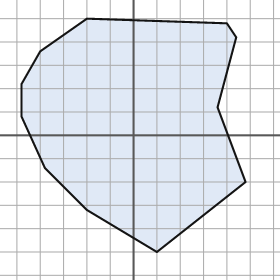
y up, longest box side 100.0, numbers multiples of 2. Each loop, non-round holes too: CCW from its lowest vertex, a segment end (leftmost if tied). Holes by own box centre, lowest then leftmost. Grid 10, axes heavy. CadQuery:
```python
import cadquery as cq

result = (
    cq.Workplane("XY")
    .moveTo(10.0, -50.0)
    .lineTo(48.0, -20.0)
    .lineTo(36.0, 12.0)
    .lineTo(44.0, 42.0)
    .lineTo(40.0, 48.0)
    .lineTo(-20.0, 50.0)
    .lineTo(-40.0, 36.0)
    .lineTo(-48.0, 22.0)
    .lineTo(-48.0, 8.0)
    .lineTo(-38.0, -14.0)
    .lineTo(-20.0, -32.0)
    .close()
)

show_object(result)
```